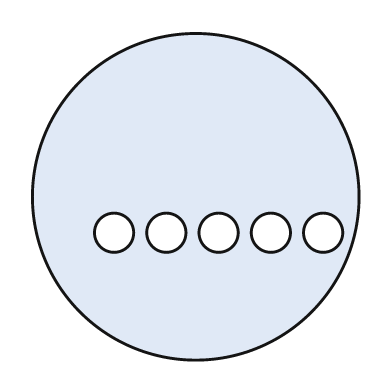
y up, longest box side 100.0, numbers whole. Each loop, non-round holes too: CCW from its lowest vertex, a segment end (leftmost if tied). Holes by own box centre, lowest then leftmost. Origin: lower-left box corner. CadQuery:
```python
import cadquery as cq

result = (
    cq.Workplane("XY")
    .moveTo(50.0, 50.0)
    .circle(50.0)
    .moveTo(25.0, 39.0)
    .circle(6.0)
    .moveTo(41.0, 39.0)
    .circle(6.0)
    .moveTo(57.0, 39.0)
    .circle(6.0)
    .moveTo(73.0, 39.0)
    .circle(6.0)
    .moveTo(89.0, 39.0)
    .circle(6.0)
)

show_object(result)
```